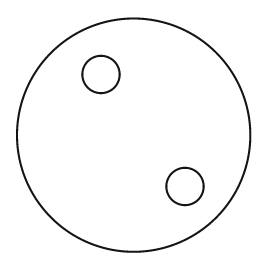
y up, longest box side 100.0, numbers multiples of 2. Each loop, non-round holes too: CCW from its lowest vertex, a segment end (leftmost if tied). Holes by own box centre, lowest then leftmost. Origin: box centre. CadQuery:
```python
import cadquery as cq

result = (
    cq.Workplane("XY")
    .moveTo(0.0, 0.0)
    .circle(50.0)
    .moveTo(22.0, -22.0)
    .circle(8.0)
    .moveTo(-14.0, 26.0)
    .circle(8.0)
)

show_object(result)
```